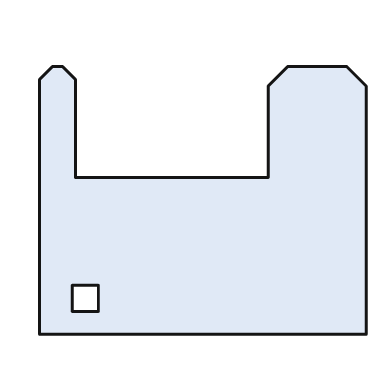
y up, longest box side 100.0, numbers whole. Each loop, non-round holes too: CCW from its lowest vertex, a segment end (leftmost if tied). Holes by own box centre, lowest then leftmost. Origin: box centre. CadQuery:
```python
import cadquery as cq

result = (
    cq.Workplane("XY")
    .moveTo(-50.0, -41.0)
    .lineTo(50.0, -41.0)
    .lineTo(50.0, 35.0)
    .lineTo(44.0, 41.0)
    .lineTo(26.0, 41.0)
    .lineTo(20.0, 35.0)
    .lineTo(20.0, 7.0)
    .lineTo(-39.0, 7.0)
    .lineTo(-39.0, 37.0)
    .lineTo(-43.0, 41.0)
    .lineTo(-46.0, 41.0)
    .lineTo(-50.0, 37.0)
    .close()
    .moveTo(-40.0, -34.0)
    .lineTo(-32.0, -34.0)
    .lineTo(-32.0, -26.0)
    .lineTo(-40.0, -26.0)
    .close()
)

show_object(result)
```